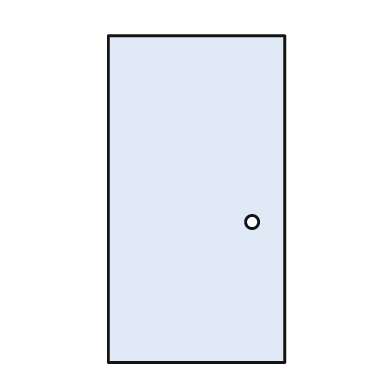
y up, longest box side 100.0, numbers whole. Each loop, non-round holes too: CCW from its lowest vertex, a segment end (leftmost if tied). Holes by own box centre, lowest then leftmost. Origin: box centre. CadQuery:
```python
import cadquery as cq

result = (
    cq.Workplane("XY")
    .moveTo(-27.0, -50.0)
    .lineTo(27.0, -50.0)
    .lineTo(27.0, 50.0)
    .lineTo(-27.0, 50.0)
    .close()
    .moveTo(17.0, -7.0)
    .circle(2.0)
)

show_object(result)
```